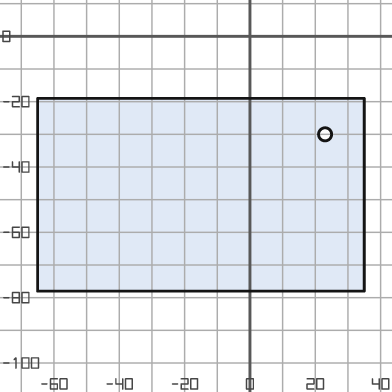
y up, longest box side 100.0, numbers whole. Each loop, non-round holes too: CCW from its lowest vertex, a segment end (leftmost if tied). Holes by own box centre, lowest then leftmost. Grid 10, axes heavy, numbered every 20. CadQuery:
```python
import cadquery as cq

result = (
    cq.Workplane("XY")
    .moveTo(-65.0, -78.0)
    .lineTo(35.0, -78.0)
    .lineTo(35.0, -19.0)
    .lineTo(-65.0, -19.0)
    .close()
    .moveTo(23.0, -30.0)
    .circle(2.0)
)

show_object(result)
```